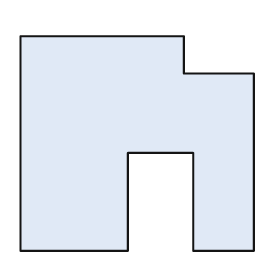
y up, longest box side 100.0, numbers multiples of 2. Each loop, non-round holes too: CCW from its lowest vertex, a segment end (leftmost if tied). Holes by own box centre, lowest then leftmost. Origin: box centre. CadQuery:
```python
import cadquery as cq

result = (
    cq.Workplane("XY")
    .moveTo(-50.0, -46.0)
    .lineTo(-4.0, -46.0)
    .lineTo(-4.0, -4.0)
    .lineTo(24.0, -4.0)
    .lineTo(24.0, -46.0)
    .lineTo(50.0, -46.0)
    .lineTo(50.0, 30.0)
    .lineTo(20.0, 30.0)
    .lineTo(20.0, 46.0)
    .lineTo(-50.0, 46.0)
    .close()
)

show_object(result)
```